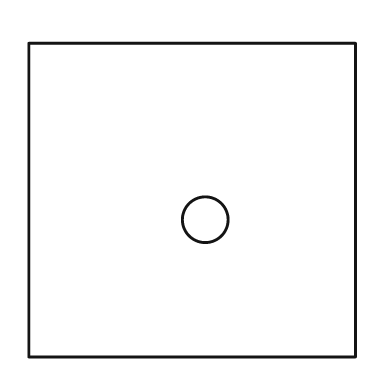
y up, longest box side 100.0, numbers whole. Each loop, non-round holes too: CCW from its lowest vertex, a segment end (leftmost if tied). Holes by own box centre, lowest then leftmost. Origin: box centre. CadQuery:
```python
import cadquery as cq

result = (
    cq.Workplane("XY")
    .moveTo(-50.0, -48.0)
    .lineTo(50.0, -48.0)
    .lineTo(50.0, 48.0)
    .lineTo(-50.0, 48.0)
    .close()
    .moveTo(4.0, -6.0)
    .circle(7.0)
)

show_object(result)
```